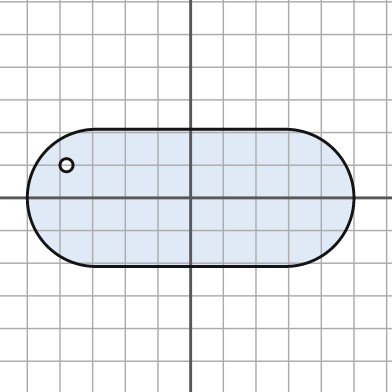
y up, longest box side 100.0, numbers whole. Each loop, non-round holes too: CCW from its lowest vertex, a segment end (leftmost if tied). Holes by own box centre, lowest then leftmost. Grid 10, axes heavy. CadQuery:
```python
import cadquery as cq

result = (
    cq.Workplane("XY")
    .moveTo(-29.0, -21.0)
    .lineTo(29.0, -21.0)
    .threePointArc((50.0, 0.0), (29.0, 21.0))
    .lineTo(-29.0, 21.0)
    .threePointArc((-50.0, 0.0), (-29.0, -21.0))
    .close()
    .moveTo(-38.0, 10.0)
    .circle(2.0)
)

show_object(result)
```